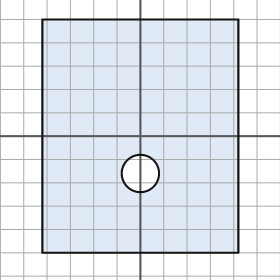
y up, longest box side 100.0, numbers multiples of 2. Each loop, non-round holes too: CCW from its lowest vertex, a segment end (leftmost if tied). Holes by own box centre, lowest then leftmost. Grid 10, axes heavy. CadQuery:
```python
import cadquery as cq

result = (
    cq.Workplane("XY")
    .moveTo(-42.0, -50.0)
    .lineTo(42.0, -50.0)
    .lineTo(42.0, 50.0)
    .lineTo(-42.0, 50.0)
    .close()
    .moveTo(0.0, -16.0)
    .circle(8.0)
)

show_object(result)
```